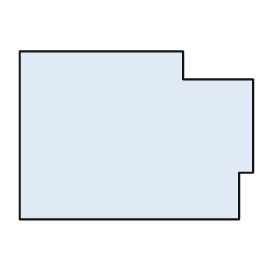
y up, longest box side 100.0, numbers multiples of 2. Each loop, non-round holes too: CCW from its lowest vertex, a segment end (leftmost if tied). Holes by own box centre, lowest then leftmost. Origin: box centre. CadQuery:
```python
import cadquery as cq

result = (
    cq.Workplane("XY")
    .moveTo(-50.0, -36.0)
    .lineTo(44.0, -36.0)
    .lineTo(44.0, -16.0)
    .lineTo(50.0, -16.0)
    .lineTo(50.0, 24.0)
    .lineTo(20.0, 24.0)
    .lineTo(20.0, 36.0)
    .lineTo(-50.0, 36.0)
    .close()
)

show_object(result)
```